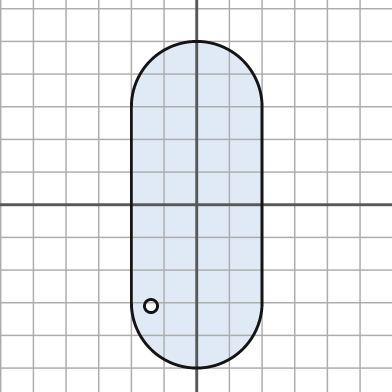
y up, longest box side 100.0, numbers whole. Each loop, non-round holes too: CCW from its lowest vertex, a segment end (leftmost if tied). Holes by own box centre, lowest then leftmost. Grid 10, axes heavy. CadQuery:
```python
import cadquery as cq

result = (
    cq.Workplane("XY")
    .moveTo(-20.0, -30.0)
    .threePointArc((0.0, -50.0), (20.0, -30.0))
    .lineTo(20.0, 30.0)
    .threePointArc((0.0, 50.0), (-20.0, 30.0))
    .close()
    .moveTo(-14.0, -31.0)
    .circle(2.0)
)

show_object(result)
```